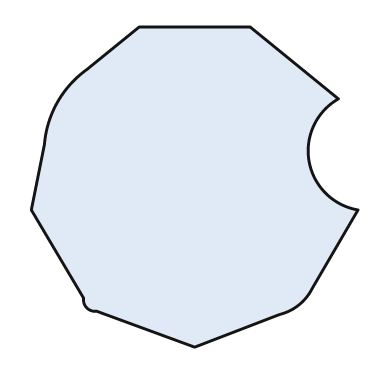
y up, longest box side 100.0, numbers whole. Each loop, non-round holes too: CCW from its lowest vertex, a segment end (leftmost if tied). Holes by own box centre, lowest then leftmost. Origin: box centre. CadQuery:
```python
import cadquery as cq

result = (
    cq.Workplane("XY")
    .moveTo(0.0, -49.0)
    .lineTo(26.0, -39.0)
    .threePointArc((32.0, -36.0), (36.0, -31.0))
    .lineTo(50.0, -7.0)
    .threePointArc((35.0, 8.0), (44.0, 27.0))
    .lineTo(17.0, 49.0)
    .lineTo(-17.0, 49.0)
    .lineTo(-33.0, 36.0)
    .threePointArc((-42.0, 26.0), (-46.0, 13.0))
    .lineTo(-50.0, -7.0)
    .lineTo(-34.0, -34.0)
    .threePointArc((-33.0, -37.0), (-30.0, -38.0))
    .close()
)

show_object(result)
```